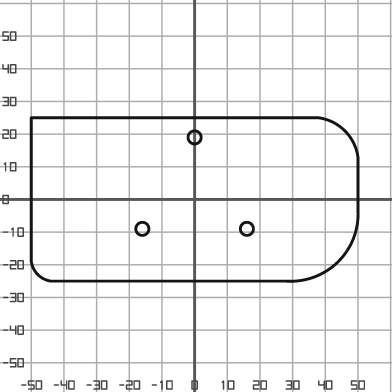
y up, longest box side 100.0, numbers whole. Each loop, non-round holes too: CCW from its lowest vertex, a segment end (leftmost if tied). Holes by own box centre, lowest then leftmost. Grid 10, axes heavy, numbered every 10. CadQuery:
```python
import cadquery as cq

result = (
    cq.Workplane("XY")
    .moveTo(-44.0, -25.0)
    .lineTo(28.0, -25.0)
    .threePointArc((44.0, -19.0), (50.0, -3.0))
    .lineTo(50.0, 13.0)
    .threePointArc((46.0, 21.0), (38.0, 25.0))
    .lineTo(-50.0, 25.0)
    .lineTo(-50.0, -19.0)
    .threePointArc((-48.0, -23.0), (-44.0, -25.0))
    .close()
    .moveTo(-16.0, -9.0)
    .circle(2.0)
    .moveTo(16.0, -9.0)
    .circle(2.0)
    .moveTo(0.0, 19.0)
    .circle(2.0)
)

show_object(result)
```